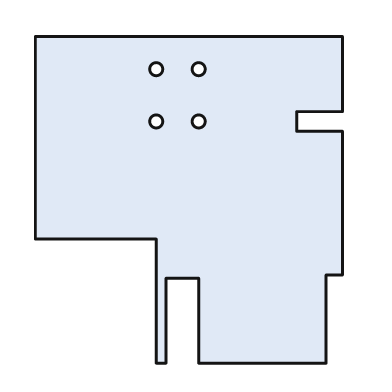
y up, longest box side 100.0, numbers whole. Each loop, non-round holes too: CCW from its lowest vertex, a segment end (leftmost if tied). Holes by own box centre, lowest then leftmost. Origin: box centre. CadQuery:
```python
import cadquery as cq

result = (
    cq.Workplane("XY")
    .moveTo(-10.0, -50.0)
    .lineTo(-7.0, -50.0)
    .lineTo(-7.0, -24.0)
    .lineTo(3.0, -24.0)
    .lineTo(3.0, -50.0)
    .lineTo(42.0, -50.0)
    .lineTo(42.0, -23.0)
    .lineTo(47.0, -23.0)
    .lineTo(47.0, 21.0)
    .lineTo(33.0, 21.0)
    .lineTo(33.0, 27.0)
    .lineTo(47.0, 27.0)
    .lineTo(47.0, 50.0)
    .lineTo(-47.0, 50.0)
    .lineTo(-47.0, -12.0)
    .lineTo(-10.0, -12.0)
    .close()
    .moveTo(-10.0, 24.0)
    .circle(2.0)
    .moveTo(3.0, 24.0)
    .circle(2.0)
    .moveTo(-10.0, 40.0)
    .circle(2.0)
    .moveTo(3.0, 40.0)
    .circle(2.0)
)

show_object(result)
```